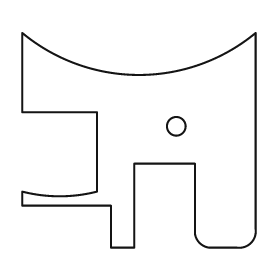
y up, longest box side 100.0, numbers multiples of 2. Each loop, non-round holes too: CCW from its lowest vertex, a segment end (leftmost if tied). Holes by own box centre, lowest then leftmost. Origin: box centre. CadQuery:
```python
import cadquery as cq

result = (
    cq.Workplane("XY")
    .moveTo(-12.0, -46.0)
    .lineTo(-2.0, -46.0)
    .lineTo(-2.0, -10.0)
    .lineTo(24.0, -10.0)
    .lineTo(24.0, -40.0)
    .threePointArc((26.0, -44.0), (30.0, -46.0))
    .lineTo(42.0, -46.0)
    .threePointArc((48.0, -44.0), (50.0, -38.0))
    .lineTo(50.0, 46.0)
    .threePointArc((0.0, 28.0), (-50.0, 46.0))
    .lineTo(-50.0, 12.0)
    .lineTo(-18.0, 12.0)
    .lineTo(-18.0, -22.0)
    .threePointArc((-34.0, -24.0), (-50.0, -22.0))
    .lineTo(-50.0, -28.0)
    .lineTo(-12.0, -28.0)
    .close()
    .moveTo(16.0, 6.0)
    .circle(4.0)
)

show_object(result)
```